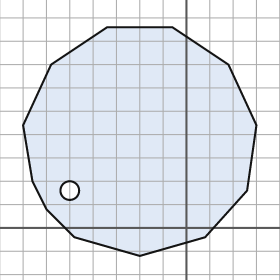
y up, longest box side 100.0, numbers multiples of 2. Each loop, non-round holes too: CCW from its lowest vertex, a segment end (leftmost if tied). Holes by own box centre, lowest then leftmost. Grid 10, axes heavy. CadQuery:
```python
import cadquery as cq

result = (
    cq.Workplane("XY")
    .moveTo(-20.0, -12.0)
    .lineTo(8.0, -4.0)
    .lineTo(26.0, 16.0)
    .lineTo(30.0, 44.0)
    .lineTo(18.0, 70.0)
    .lineTo(-6.0, 86.0)
    .lineTo(-34.0, 86.0)
    .lineTo(-58.0, 70.0)
    .lineTo(-70.0, 44.0)
    .lineTo(-66.0, 20.0)
    .lineTo(-60.0, 8.0)
    .lineTo(-48.0, -4.0)
    .close()
    .moveTo(-50.0, 16.0)
    .circle(4.0)
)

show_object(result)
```